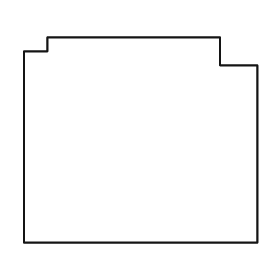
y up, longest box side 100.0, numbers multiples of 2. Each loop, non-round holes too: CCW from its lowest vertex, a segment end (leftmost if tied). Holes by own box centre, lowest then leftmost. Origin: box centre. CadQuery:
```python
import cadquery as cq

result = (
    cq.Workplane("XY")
    .moveTo(-50.0, -44.0)
    .lineTo(50.0, -44.0)
    .lineTo(50.0, 32.0)
    .lineTo(34.0, 32.0)
    .lineTo(34.0, 44.0)
    .lineTo(-40.0, 44.0)
    .lineTo(-40.0, 38.0)
    .lineTo(-50.0, 38.0)
    .close()
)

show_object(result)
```